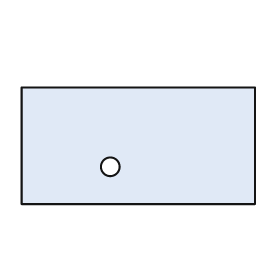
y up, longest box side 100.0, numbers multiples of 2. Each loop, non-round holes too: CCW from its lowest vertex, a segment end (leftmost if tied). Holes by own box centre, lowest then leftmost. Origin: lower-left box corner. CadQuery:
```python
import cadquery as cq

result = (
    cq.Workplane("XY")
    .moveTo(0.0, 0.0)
    .lineTo(100.0, 0.0)
    .lineTo(100.0, 50.0)
    .lineTo(0.0, 50.0)
    .close()
    .moveTo(38.0, 16.0)
    .circle(4.0)
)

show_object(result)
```